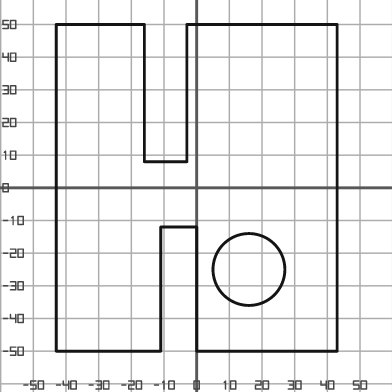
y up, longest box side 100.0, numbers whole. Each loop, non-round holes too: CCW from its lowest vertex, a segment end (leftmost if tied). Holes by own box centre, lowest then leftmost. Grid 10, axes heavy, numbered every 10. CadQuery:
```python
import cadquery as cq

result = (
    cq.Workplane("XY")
    .moveTo(-43.0, -50.0)
    .lineTo(-11.0, -50.0)
    .lineTo(-11.0, -12.0)
    .lineTo(0.0, -12.0)
    .lineTo(0.0, -50.0)
    .lineTo(43.0, -50.0)
    .lineTo(43.0, 50.0)
    .lineTo(-3.0, 50.0)
    .lineTo(-3.0, 8.0)
    .lineTo(-16.0, 8.0)
    .lineTo(-16.0, 50.0)
    .lineTo(-43.0, 50.0)
    .close()
    .moveTo(16.0, -25.0)
    .circle(11.0)
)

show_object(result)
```